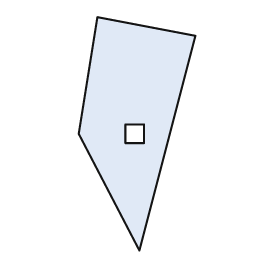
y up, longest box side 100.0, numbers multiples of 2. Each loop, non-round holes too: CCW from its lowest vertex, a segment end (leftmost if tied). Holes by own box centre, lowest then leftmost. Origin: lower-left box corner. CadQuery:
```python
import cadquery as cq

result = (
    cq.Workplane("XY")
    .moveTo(26.0, 0.0)
    .lineTo(50.0, 92.0)
    .lineTo(8.0, 100.0)
    .lineTo(0.0, 50.0)
    .close()
    .moveTo(20.0, 46.0)
    .lineTo(28.0, 46.0)
    .lineTo(28.0, 54.0)
    .lineTo(20.0, 54.0)
    .close()
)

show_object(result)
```